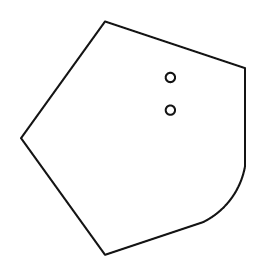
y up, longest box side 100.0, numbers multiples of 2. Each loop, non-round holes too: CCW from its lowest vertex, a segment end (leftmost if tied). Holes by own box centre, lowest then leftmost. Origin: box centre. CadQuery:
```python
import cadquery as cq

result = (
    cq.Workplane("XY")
    .moveTo(-12.0, -50.0)
    .lineTo(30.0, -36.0)
    .threePointArc((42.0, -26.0), (48.0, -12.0))
    .lineTo(48.0, 30.0)
    .lineTo(-12.0, 50.0)
    .lineTo(-48.0, 0.0)
    .close()
    .moveTo(16.0, 12.0)
    .circle(2.0)
    .moveTo(16.0, 26.0)
    .circle(2.0)
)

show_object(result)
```